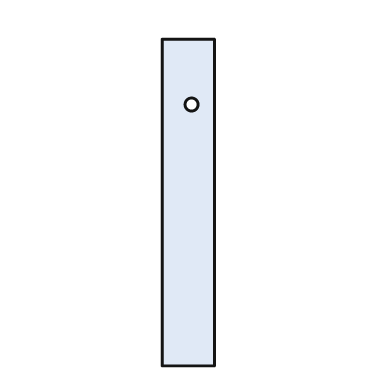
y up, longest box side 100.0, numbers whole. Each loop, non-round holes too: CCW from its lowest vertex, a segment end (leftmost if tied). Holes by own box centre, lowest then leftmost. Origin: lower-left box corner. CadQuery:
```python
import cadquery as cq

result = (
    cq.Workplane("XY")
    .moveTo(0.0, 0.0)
    .lineTo(16.0, 0.0)
    .lineTo(16.0, 100.0)
    .lineTo(0.0, 100.0)
    .close()
    .moveTo(9.0, 80.0)
    .circle(2.0)
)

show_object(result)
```